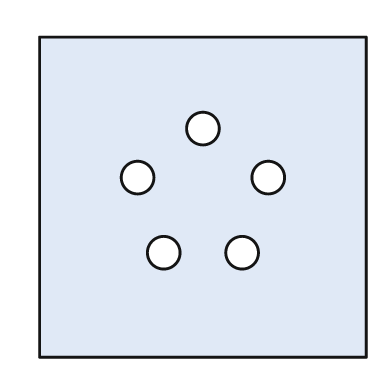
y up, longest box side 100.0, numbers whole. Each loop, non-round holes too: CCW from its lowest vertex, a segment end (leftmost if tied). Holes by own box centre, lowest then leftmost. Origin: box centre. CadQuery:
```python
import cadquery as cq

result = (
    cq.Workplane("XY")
    .moveTo(-50.0, -49.0)
    .lineTo(50.0, -49.0)
    .lineTo(50.0, 49.0)
    .lineTo(-50.0, 49.0)
    .close()
    .moveTo(-12.0, -17.0)
    .circle(5.0)
    .moveTo(12.0, -17.0)
    .circle(5.0)
    .moveTo(-20.0, 6.0)
    .circle(5.0)
    .moveTo(20.0, 6.0)
    .circle(5.0)
    .moveTo(0.0, 21.0)
    .circle(5.0)
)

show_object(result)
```